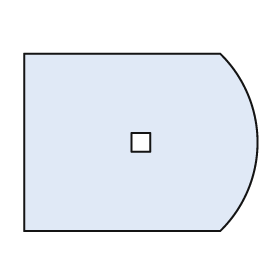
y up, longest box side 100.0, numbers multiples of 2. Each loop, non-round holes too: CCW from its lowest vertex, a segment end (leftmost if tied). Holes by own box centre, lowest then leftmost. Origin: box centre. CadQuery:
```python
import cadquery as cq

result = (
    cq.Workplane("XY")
    .moveTo(-50.0, -38.0)
    .lineTo(34.0, -38.0)
    .threePointArc((50.0, 0.0), (34.0, 38.0))
    .lineTo(-50.0, 38.0)
    .close()
    .moveTo(-4.0, -4.0)
    .lineTo(4.0, -4.0)
    .lineTo(4.0, 4.0)
    .lineTo(-4.0, 4.0)
    .close()
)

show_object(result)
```